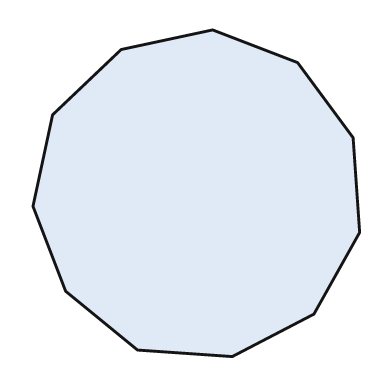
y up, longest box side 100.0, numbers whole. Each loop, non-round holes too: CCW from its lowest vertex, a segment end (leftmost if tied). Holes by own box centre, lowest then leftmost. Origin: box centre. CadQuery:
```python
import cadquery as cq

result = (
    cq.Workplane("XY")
    .moveTo(11.0, -50.0)
    .lineTo(36.0, -37.0)
    .lineTo(50.0, -12.0)
    .lineTo(48.0, 17.0)
    .lineTo(31.0, 40.0)
    .lineTo(5.0, 50.0)
    .lineTo(-23.0, 44.0)
    .lineTo(-44.0, 24.0)
    .lineTo(-50.0, -4.0)
    .lineTo(-40.0, -30.0)
    .lineTo(-18.0, -48.0)
    .close()
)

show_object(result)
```